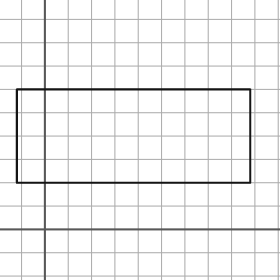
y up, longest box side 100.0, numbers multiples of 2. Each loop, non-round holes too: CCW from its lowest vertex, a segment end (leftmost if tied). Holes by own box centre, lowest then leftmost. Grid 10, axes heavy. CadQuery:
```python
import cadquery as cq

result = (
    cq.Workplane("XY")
    .moveTo(-12.0, 20.0)
    .lineTo(88.0, 20.0)
    .lineTo(88.0, 60.0)
    .lineTo(-12.0, 60.0)
    .close()
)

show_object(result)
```